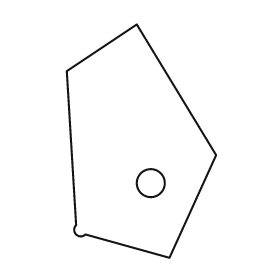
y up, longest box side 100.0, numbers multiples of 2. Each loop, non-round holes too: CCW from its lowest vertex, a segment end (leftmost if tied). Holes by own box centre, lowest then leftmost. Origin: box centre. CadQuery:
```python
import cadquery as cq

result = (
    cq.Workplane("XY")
    .moveTo(12.0, -50.0)
    .lineTo(32.0, -6.0)
    .lineTo(-2.0, 50.0)
    .lineTo(-32.0, 30.0)
    .lineTo(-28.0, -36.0)
    .threePointArc((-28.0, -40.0), (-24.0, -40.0))
    .close()
    .moveTo(4.0, -18.0)
    .circle(6.0)
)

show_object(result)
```